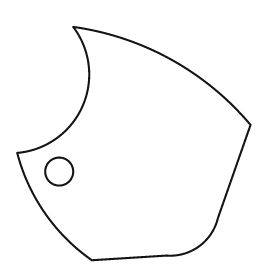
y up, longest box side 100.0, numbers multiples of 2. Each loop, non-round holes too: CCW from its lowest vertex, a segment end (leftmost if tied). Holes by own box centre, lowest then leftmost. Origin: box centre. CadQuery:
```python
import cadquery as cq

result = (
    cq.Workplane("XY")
    .moveTo(-18.0, -50.0)
    .lineTo(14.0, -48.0)
    .threePointArc((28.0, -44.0), (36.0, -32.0))
    .lineTo(50.0, 8.0)
    .threePointArc((16.0, 36.0), (-26.0, 50.0))
    .threePointArc((-22.0, 16.0), (-50.0, -4.0))
    .threePointArc((-38.0, -30.0), (-18.0, -50.0))
    .close()
    .moveTo(-32.0, -12.0)
    .circle(6.0)
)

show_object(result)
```